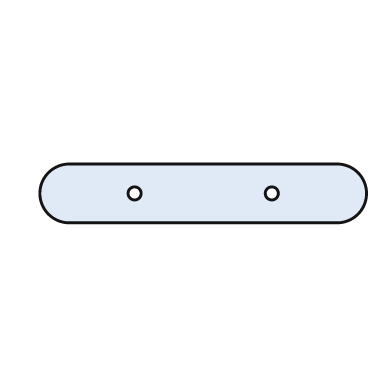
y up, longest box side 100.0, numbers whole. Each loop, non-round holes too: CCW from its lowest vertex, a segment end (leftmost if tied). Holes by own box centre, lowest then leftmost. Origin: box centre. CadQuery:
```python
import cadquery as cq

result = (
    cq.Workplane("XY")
    .moveTo(-41.0, -9.0)
    .lineTo(41.0, -9.0)
    .threePointArc((50.0, 0.0), (41.0, 9.0))
    .lineTo(-41.0, 9.0)
    .threePointArc((-50.0, 0.0), (-41.0, -9.0))
    .close()
    .moveTo(-21.0, 0.0)
    .circle(2.0)
    .moveTo(21.0, 0.0)
    .circle(2.0)
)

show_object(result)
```